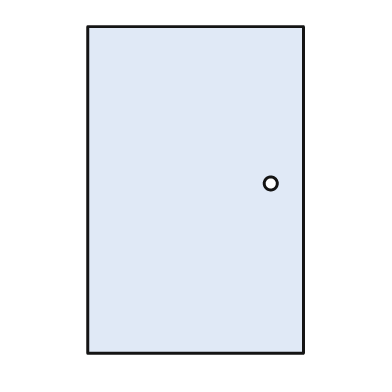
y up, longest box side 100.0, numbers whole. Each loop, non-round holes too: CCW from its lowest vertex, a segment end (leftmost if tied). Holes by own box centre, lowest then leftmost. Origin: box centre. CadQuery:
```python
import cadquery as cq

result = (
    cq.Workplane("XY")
    .moveTo(-33.0, -50.0)
    .lineTo(33.0, -50.0)
    .lineTo(33.0, 50.0)
    .lineTo(-33.0, 50.0)
    .close()
    .moveTo(23.0, 2.0)
    .circle(2.0)
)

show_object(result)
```